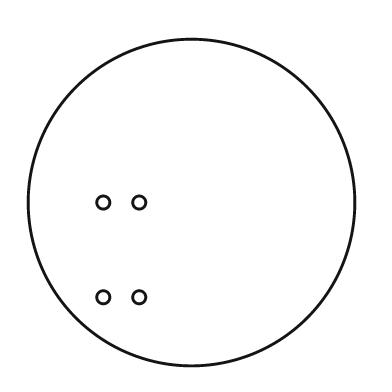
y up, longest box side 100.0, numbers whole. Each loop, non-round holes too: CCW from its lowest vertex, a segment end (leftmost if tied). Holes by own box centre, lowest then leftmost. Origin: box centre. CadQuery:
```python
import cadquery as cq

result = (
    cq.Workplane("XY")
    .moveTo(0.0, 0.0)
    .circle(50.0)
    .moveTo(-27.0, -29.0)
    .circle(2.0)
    .moveTo(-16.0, -29.0)
    .circle(2.0)
    .moveTo(-27.0, 0.0)
    .circle(2.0)
    .moveTo(-16.0, 0.0)
    .circle(2.0)
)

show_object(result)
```